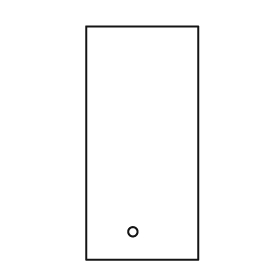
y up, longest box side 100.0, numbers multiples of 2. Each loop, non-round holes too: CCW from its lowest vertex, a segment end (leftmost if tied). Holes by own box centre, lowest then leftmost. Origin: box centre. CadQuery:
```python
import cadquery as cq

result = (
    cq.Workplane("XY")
    .moveTo(-24.0, -50.0)
    .lineTo(24.0, -50.0)
    .lineTo(24.0, 50.0)
    .lineTo(-24.0, 50.0)
    .close()
    .moveTo(-4.0, -38.0)
    .circle(2.0)
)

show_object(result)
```